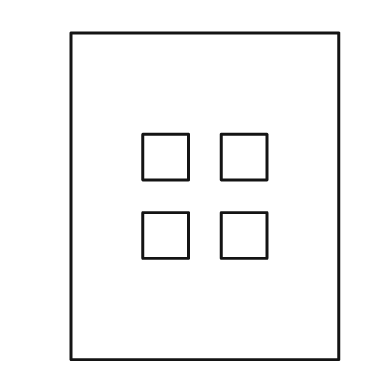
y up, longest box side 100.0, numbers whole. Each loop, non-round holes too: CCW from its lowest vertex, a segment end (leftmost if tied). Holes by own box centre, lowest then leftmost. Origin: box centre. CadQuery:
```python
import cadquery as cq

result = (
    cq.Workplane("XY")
    .moveTo(-41.0, -50.0)
    .lineTo(41.0, -50.0)
    .lineTo(41.0, 50.0)
    .lineTo(-41.0, 50.0)
    .close()
    .moveTo(-19.0, -19.0)
    .lineTo(-5.0, -19.0)
    .lineTo(-5.0, -5.0)
    .lineTo(-19.0, -5.0)
    .close()
    .moveTo(5.0, -19.0)
    .lineTo(19.0, -19.0)
    .lineTo(19.0, -5.0)
    .lineTo(5.0, -5.0)
    .close()
    .moveTo(-19.0, 5.0)
    .lineTo(-5.0, 5.0)
    .lineTo(-5.0, 19.0)
    .lineTo(-19.0, 19.0)
    .close()
    .moveTo(5.0, 5.0)
    .lineTo(19.0, 5.0)
    .lineTo(19.0, 19.0)
    .lineTo(5.0, 19.0)
    .close()
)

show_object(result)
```